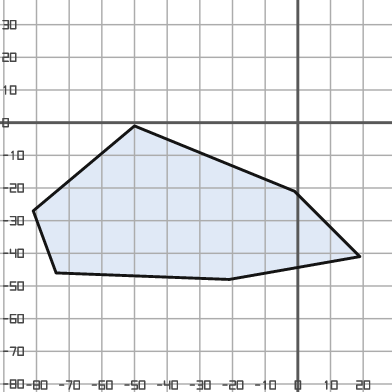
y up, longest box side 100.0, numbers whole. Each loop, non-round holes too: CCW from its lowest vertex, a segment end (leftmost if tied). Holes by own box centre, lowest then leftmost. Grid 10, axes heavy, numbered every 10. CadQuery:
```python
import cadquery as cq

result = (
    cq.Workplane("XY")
    .moveTo(-21.0, -48.0)
    .lineTo(19.0, -41.0)
    .lineTo(-1.0, -21.0)
    .lineTo(-50.0, -1.0)
    .lineTo(-81.0, -27.0)
    .lineTo(-74.0, -46.0)
    .close()
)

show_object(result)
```